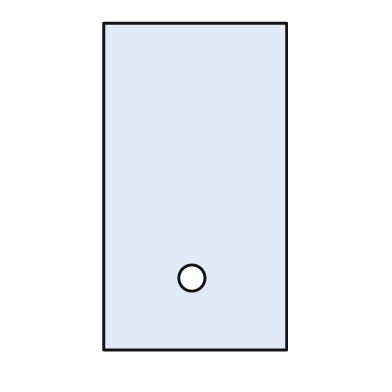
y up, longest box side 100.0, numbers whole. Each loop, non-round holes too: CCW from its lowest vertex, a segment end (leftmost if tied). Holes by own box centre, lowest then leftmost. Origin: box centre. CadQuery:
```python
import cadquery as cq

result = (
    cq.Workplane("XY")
    .moveTo(-28.0, -50.0)
    .lineTo(28.0, -50.0)
    .lineTo(28.0, 50.0)
    .lineTo(-28.0, 50.0)
    .close()
    .moveTo(-1.0, -28.0)
    .circle(4.0)
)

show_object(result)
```